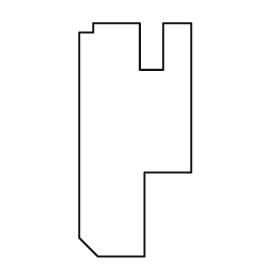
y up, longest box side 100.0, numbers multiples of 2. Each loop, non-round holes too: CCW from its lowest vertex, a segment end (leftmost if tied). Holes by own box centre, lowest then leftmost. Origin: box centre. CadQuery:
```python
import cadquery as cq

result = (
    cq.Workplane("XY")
    .moveTo(-16.0, -50.0)
    .lineTo(4.0, -50.0)
    .lineTo(4.0, -14.0)
    .lineTo(24.0, -14.0)
    .lineTo(24.0, 50.0)
    .lineTo(12.0, 50.0)
    .lineTo(12.0, 30.0)
    .lineTo(2.0, 30.0)
    .lineTo(2.0, 50.0)
    .lineTo(-18.0, 50.0)
    .lineTo(-18.0, 46.0)
    .lineTo(-24.0, 46.0)
    .lineTo(-24.0, -42.0)
    .close()
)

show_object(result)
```